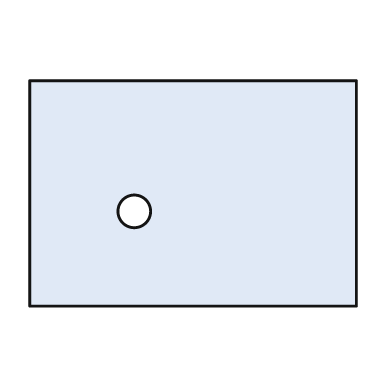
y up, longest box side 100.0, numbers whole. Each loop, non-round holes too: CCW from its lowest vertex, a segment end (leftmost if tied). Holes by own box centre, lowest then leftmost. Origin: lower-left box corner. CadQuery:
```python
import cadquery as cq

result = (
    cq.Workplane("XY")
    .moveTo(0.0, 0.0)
    .lineTo(100.0, 0.0)
    .lineTo(100.0, 69.0)
    .lineTo(0.0, 69.0)
    .close()
    .moveTo(32.0, 29.0)
    .circle(5.0)
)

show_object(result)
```